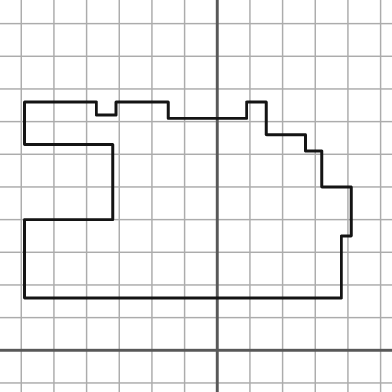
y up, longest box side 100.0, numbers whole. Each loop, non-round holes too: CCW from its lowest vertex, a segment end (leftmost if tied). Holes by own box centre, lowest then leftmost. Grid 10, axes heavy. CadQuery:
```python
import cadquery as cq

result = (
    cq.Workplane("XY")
    .moveTo(-59.0, 16.0)
    .lineTo(38.0, 16.0)
    .lineTo(38.0, 35.0)
    .lineTo(41.0, 35.0)
    .lineTo(41.0, 50.0)
    .lineTo(32.0, 50.0)
    .lineTo(32.0, 61.0)
    .lineTo(27.0, 61.0)
    .lineTo(27.0, 66.0)
    .lineTo(15.0, 66.0)
    .lineTo(15.0, 76.0)
    .lineTo(9.0, 76.0)
    .lineTo(9.0, 71.0)
    .lineTo(-15.0, 71.0)
    .lineTo(-15.0, 76.0)
    .lineTo(-31.0, 76.0)
    .lineTo(-31.0, 72.0)
    .lineTo(-37.0, 72.0)
    .lineTo(-37.0, 76.0)
    .lineTo(-59.0, 76.0)
    .lineTo(-59.0, 63.0)
    .lineTo(-32.0, 63.0)
    .lineTo(-32.0, 40.0)
    .lineTo(-59.0, 40.0)
    .close()
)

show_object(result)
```